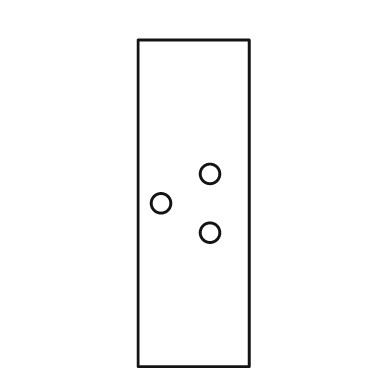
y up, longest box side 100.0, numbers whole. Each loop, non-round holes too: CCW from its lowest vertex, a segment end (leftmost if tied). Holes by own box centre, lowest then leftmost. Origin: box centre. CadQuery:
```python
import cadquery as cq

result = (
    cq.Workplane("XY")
    .moveTo(-17.0, -50.0)
    .lineTo(17.0, -50.0)
    .lineTo(17.0, 50.0)
    .lineTo(-17.0, 50.0)
    .close()
    .moveTo(5.0, -9.0)
    .circle(3.0)
    .moveTo(-10.0, 0.0)
    .circle(3.0)
    .moveTo(5.0, 9.0)
    .circle(3.0)
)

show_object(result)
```